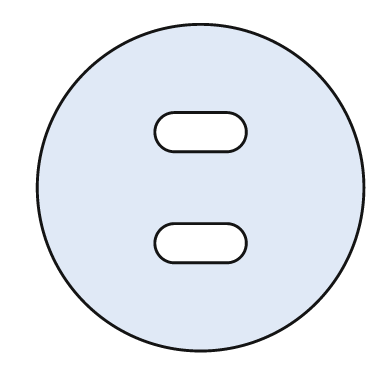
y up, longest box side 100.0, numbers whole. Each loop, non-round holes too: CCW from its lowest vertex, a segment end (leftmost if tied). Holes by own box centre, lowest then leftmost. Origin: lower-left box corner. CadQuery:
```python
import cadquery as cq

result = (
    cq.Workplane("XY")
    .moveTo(50.0, 50.0)
    .circle(50.0)
    .moveTo(42.0, 27.0)
    .lineTo(58.0, 27.0)
    .threePointArc((64.0, 33.0), (58.0, 39.0))
    .lineTo(42.0, 39.0)
    .threePointArc((36.0, 33.0), (42.0, 27.0))
    .close()
    .moveTo(42.0, 61.0)
    .lineTo(58.0, 61.0)
    .threePointArc((64.0, 67.0), (58.0, 73.0))
    .lineTo(42.0, 73.0)
    .threePointArc((36.0, 67.0), (42.0, 61.0))
    .close()
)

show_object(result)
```